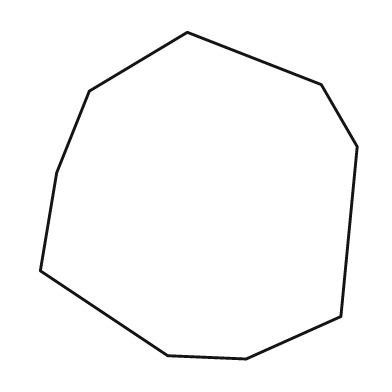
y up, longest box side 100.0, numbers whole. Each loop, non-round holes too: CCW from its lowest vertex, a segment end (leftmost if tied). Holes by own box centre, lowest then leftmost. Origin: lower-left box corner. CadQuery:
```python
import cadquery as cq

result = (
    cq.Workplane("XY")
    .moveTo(63.0, 0.0)
    .lineTo(92.0, 13.0)
    .lineTo(97.0, 65.0)
    .lineTo(86.0, 84.0)
    .lineTo(45.0, 100.0)
    .lineTo(15.0, 82.0)
    .lineTo(5.0, 57.0)
    .lineTo(0.0, 27.0)
    .lineTo(39.0, 1.0)
    .close()
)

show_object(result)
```